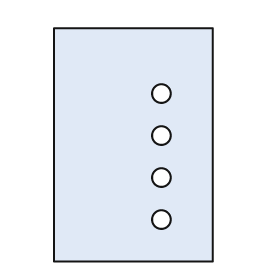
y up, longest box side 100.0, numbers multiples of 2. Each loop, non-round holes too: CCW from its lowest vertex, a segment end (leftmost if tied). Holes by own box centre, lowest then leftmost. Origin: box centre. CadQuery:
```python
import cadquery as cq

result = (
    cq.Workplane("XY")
    .moveTo(-34.0, -50.0)
    .lineTo(34.0, -50.0)
    .lineTo(34.0, 50.0)
    .lineTo(-34.0, 50.0)
    .close()
    .moveTo(12.0, -32.0)
    .circle(4.0)
    .moveTo(12.0, -14.0)
    .circle(4.0)
    .moveTo(12.0, 4.0)
    .circle(4.0)
    .moveTo(12.0, 22.0)
    .circle(4.0)
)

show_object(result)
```